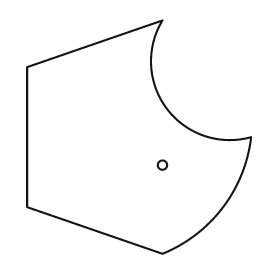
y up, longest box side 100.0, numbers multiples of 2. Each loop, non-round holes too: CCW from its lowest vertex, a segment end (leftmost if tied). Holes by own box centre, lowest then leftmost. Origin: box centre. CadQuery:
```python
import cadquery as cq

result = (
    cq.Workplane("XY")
    .moveTo(10.0, -50.0)
    .threePointArc((36.0, -30.0), (48.0, 0.0))
    .threePointArc((12.0, 12.0), (10.0, 50.0))
    .lineTo(-48.0, 30.0)
    .lineTo(-48.0, -30.0)
    .close()
    .moveTo(10.0, -12.0)
    .circle(2.0)
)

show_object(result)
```